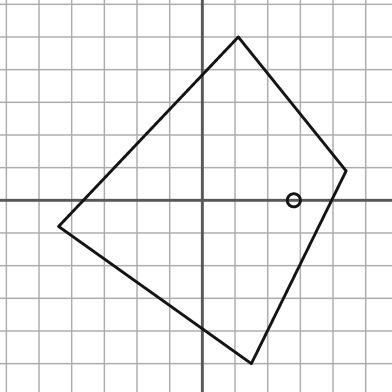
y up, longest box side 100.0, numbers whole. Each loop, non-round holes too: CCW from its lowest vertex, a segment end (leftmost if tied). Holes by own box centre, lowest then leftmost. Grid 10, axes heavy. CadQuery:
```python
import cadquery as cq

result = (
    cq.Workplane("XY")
    .moveTo(15.0, -50.0)
    .lineTo(44.0, 9.0)
    .lineTo(11.0, 50.0)
    .lineTo(-44.0, -8.0)
    .close()
    .moveTo(28.0, 0.0)
    .circle(2.0)
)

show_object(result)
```